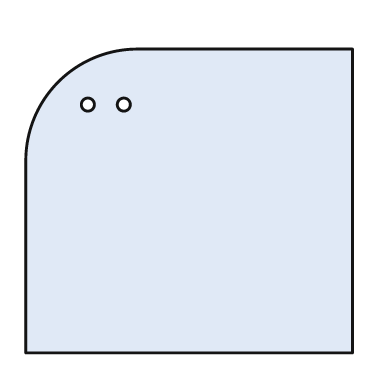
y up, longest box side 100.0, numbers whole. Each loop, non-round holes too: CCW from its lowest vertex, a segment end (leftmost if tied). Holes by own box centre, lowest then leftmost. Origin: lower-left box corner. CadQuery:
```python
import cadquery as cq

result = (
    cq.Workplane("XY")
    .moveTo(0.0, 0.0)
    .lineTo(100.0, 0.0)
    .lineTo(100.0, 93.0)
    .lineTo(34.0, 93.0)
    .threePointArc((10.0, 83.0), (0.0, 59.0))
    .close()
    .moveTo(19.0, 76.0)
    .circle(2.0)
    .moveTo(30.0, 76.0)
    .circle(2.0)
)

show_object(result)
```